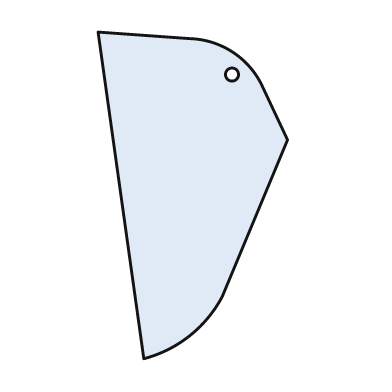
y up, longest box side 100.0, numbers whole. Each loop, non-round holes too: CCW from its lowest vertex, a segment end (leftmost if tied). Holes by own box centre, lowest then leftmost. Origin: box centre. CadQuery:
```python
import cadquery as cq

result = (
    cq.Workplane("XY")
    .moveTo(-15.0, -50.0)
    .threePointArc((-1.0, -43.0), (9.0, -31.0))
    .lineTo(29.0, 17.0)
    .lineTo(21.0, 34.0)
    .threePointArc((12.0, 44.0), (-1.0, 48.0))
    .lineTo(-29.0, 50.0)
    .close()
    .moveTo(12.0, 37.0)
    .circle(2.0)
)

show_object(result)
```